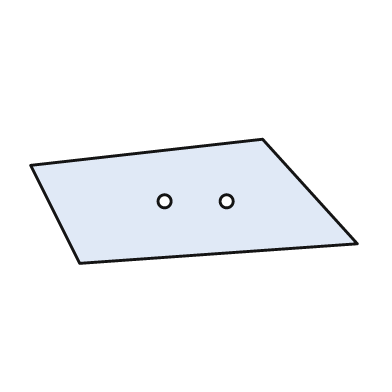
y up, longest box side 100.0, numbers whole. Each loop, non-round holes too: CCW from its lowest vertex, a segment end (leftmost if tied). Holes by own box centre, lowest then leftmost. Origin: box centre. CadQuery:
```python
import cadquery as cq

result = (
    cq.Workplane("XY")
    .moveTo(-35.0, -19.0)
    .lineTo(50.0, -13.0)
    .lineTo(21.0, 19.0)
    .lineTo(-50.0, 11.0)
    .close()
    .moveTo(-9.0, 0.0)
    .circle(2.0)
    .moveTo(10.0, 0.0)
    .circle(2.0)
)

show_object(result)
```